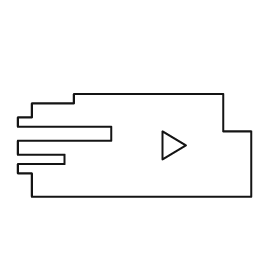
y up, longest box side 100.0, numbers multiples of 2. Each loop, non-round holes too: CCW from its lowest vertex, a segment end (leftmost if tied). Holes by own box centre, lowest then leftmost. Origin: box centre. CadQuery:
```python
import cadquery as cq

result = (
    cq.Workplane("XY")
    .moveTo(-44.0, -22.0)
    .lineTo(50.0, -22.0)
    .lineTo(50.0, 6.0)
    .lineTo(38.0, 6.0)
    .lineTo(38.0, 22.0)
    .lineTo(-26.0, 22.0)
    .lineTo(-26.0, 18.0)
    .lineTo(-44.0, 18.0)
    .lineTo(-44.0, 12.0)
    .lineTo(-50.0, 12.0)
    .lineTo(-50.0, 8.0)
    .lineTo(-10.0, 8.0)
    .lineTo(-10.0, 2.0)
    .lineTo(-50.0, 2.0)
    .lineTo(-50.0, -4.0)
    .lineTo(-30.0, -4.0)
    .lineTo(-30.0, -8.0)
    .lineTo(-50.0, -8.0)
    .lineTo(-50.0, -12.0)
    .lineTo(-44.0, -12.0)
    .close()
    .moveTo(12.0, -6.0)
    .lineTo(22.0, 0.0)
    .lineTo(12.0, 6.0)
    .close()
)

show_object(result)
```